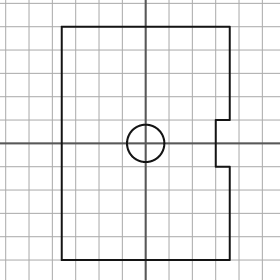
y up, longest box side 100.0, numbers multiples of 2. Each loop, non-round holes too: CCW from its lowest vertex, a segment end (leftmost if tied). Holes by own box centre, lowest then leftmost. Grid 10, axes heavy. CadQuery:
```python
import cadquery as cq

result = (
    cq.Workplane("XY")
    .moveTo(-36.0, -50.0)
    .lineTo(36.0, -50.0)
    .lineTo(36.0, -10.0)
    .lineTo(30.0, -10.0)
    .lineTo(30.0, 10.0)
    .lineTo(36.0, 10.0)
    .lineTo(36.0, 50.0)
    .lineTo(-36.0, 50.0)
    .close()
    .moveTo(0.0, 0.0)
    .circle(8.0)
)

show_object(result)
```